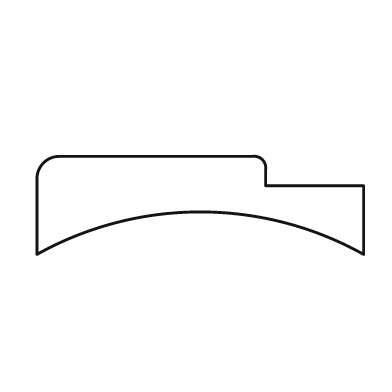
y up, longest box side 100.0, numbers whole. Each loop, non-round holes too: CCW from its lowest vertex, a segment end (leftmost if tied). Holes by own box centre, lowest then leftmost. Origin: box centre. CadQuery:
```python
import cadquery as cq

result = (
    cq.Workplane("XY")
    .moveTo(-50.0, -15.0)
    .threePointArc((0.0, -2.0), (50.0, -15.0))
    .lineTo(50.0, 6.0)
    .lineTo(20.0, 6.0)
    .lineTo(20.0, 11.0)
    .threePointArc((19.0, 14.0), (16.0, 15.0))
    .lineTo(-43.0, 15.0)
    .threePointArc((-48.0, 13.0), (-50.0, 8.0))
    .close()
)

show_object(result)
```